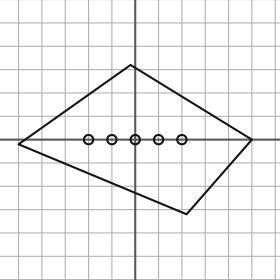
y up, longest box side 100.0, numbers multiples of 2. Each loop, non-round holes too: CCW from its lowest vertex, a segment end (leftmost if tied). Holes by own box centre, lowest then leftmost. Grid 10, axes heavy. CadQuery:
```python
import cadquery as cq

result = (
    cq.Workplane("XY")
    .moveTo(22.0, -32.0)
    .lineTo(50.0, 0.0)
    .lineTo(-2.0, 32.0)
    .lineTo(-50.0, -2.0)
    .close()
    .moveTo(-20.0, 0.0)
    .circle(2.0)
    .moveTo(-10.0, 0.0)
    .circle(2.0)
    .moveTo(0.0, 0.0)
    .circle(2.0)
    .moveTo(10.0, 0.0)
    .circle(2.0)
    .moveTo(20.0, 0.0)
    .circle(2.0)
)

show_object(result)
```